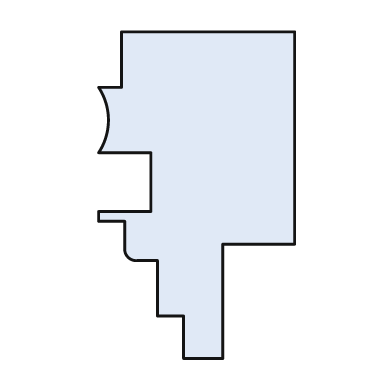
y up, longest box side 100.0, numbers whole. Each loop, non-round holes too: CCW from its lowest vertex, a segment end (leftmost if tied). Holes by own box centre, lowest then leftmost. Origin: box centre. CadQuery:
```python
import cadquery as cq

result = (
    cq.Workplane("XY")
    .moveTo(-4.0, -50.0)
    .lineTo(8.0, -50.0)
    .lineTo(8.0, -15.0)
    .lineTo(30.0, -15.0)
    .lineTo(30.0, 50.0)
    .lineTo(-23.0, 50.0)
    .lineTo(-23.0, 33.0)
    .lineTo(-30.0, 33.0)
    .threePointArc((-27.0, 23.0), (-30.0, 13.0))
    .lineTo(-14.0, 13.0)
    .lineTo(-14.0, -5.0)
    .lineTo(-30.0, -5.0)
    .lineTo(-30.0, -8.0)
    .lineTo(-22.0, -8.0)
    .lineTo(-22.0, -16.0)
    .threePointArc((-21.0, -19.0), (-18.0, -20.0))
    .lineTo(-12.0, -20.0)
    .lineTo(-12.0, -37.0)
    .lineTo(-4.0, -37.0)
    .close()
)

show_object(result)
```